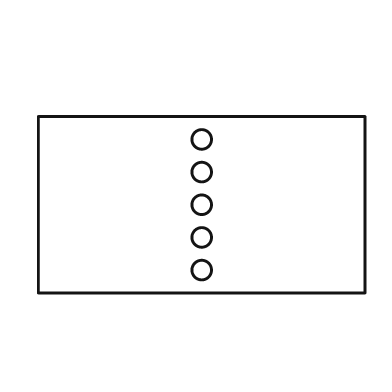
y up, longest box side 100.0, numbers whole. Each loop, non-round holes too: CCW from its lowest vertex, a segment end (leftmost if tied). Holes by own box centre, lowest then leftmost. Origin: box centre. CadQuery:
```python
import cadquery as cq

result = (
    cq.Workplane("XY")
    .moveTo(-50.0, -27.0)
    .lineTo(50.0, -27.0)
    .lineTo(50.0, 27.0)
    .lineTo(-50.0, 27.0)
    .close()
    .moveTo(0.0, -20.0)
    .circle(3.0)
    .moveTo(0.0, -10.0)
    .circle(3.0)
    .moveTo(0.0, 0.0)
    .circle(3.0)
    .moveTo(0.0, 10.0)
    .circle(3.0)
    .moveTo(0.0, 20.0)
    .circle(3.0)
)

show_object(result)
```